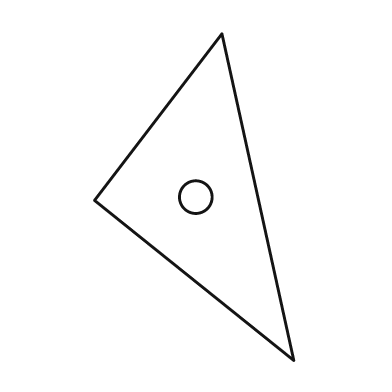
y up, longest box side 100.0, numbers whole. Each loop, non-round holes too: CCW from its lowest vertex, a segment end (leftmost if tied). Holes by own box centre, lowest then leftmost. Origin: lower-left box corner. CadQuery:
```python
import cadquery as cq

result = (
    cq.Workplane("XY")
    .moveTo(61.0, 0.0)
    .lineTo(39.0, 100.0)
    .lineTo(0.0, 49.0)
    .close()
    .moveTo(31.0, 50.0)
    .circle(5.0)
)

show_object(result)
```